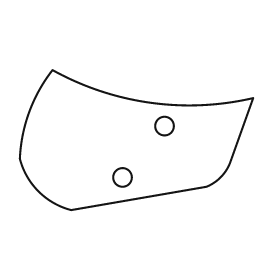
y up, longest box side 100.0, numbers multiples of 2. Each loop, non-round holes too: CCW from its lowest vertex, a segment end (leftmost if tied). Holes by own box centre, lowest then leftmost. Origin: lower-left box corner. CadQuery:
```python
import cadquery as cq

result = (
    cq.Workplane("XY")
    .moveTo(22.0, 0.0)
    .lineTo(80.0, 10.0)
    .threePointArc((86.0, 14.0), (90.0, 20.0))
    .lineTo(100.0, 48.0)
    .threePointArc((56.0, 46.0), (14.0, 60.0))
    .threePointArc((4.0, 42.0), (0.0, 22.0))
    .threePointArc((8.0, 8.0), (22.0, 0.0))
    .close()
    .moveTo(44.0, 14.0)
    .circle(4.0)
    .moveTo(62.0, 36.0)
    .circle(4.0)
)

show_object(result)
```